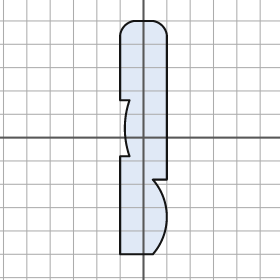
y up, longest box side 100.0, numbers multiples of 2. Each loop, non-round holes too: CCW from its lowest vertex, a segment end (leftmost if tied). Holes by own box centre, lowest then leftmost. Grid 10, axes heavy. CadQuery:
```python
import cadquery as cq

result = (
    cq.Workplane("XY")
    .moveTo(-10.0, -50.0)
    .lineTo(4.0, -50.0)
    .threePointArc((10.0, -34.0), (4.0, -18.0))
    .lineTo(10.0, -18.0)
    .lineTo(10.0, 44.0)
    .threePointArc((8.0, 48.0), (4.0, 50.0))
    .lineTo(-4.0, 50.0)
    .threePointArc((-8.0, 48.0), (-10.0, 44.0))
    .lineTo(-10.0, 16.0)
    .lineTo(-6.0, 16.0)
    .threePointArc((-8.0, 4.0), (-6.0, -8.0))
    .lineTo(-10.0, -8.0)
    .close()
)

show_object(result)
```